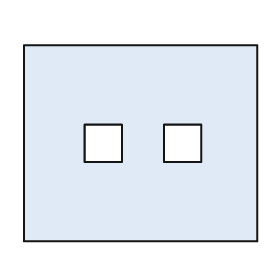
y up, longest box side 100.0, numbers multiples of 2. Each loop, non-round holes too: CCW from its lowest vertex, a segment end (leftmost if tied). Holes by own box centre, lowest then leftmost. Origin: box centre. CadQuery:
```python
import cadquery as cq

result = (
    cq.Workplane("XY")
    .moveTo(-50.0, -42.0)
    .lineTo(50.0, -42.0)
    .lineTo(50.0, 42.0)
    .lineTo(-50.0, 42.0)
    .close()
    .moveTo(-24.0, -8.0)
    .lineTo(-8.0, -8.0)
    .lineTo(-8.0, 8.0)
    .lineTo(-24.0, 8.0)
    .close()
    .moveTo(10.0, -8.0)
    .lineTo(26.0, -8.0)
    .lineTo(26.0, 8.0)
    .lineTo(10.0, 8.0)
    .close()
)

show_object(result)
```